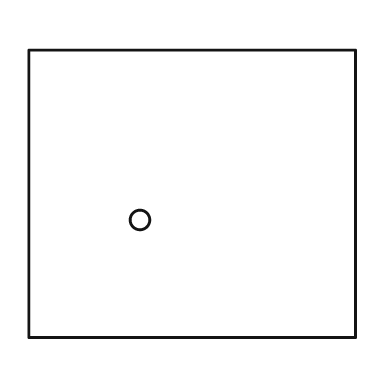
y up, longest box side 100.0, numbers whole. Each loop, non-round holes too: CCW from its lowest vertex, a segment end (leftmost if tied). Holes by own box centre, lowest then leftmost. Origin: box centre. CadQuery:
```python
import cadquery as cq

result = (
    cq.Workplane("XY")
    .moveTo(-50.0, -44.0)
    .lineTo(50.0, -44.0)
    .lineTo(50.0, 44.0)
    .lineTo(-50.0, 44.0)
    .close()
    .moveTo(-16.0, -8.0)
    .circle(3.0)
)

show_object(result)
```